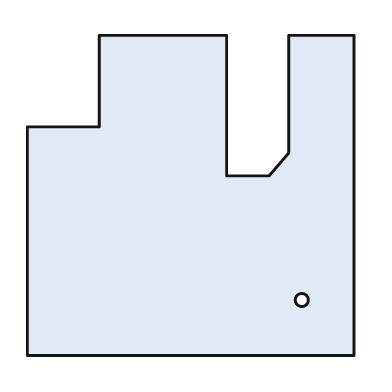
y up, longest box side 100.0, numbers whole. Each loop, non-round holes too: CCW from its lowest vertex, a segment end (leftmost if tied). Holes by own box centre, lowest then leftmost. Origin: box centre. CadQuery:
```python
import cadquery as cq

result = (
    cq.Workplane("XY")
    .moveTo(-50.0, -49.0)
    .lineTo(50.0, -49.0)
    .lineTo(50.0, 49.0)
    .lineTo(30.0, 49.0)
    .lineTo(30.0, 13.0)
    .lineTo(24.0, 6.0)
    .lineTo(11.0, 6.0)
    .lineTo(11.0, 49.0)
    .lineTo(-28.0, 49.0)
    .lineTo(-28.0, 21.0)
    .lineTo(-50.0, 21.0)
    .close()
    .moveTo(34.0, -32.0)
    .circle(2.0)
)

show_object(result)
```